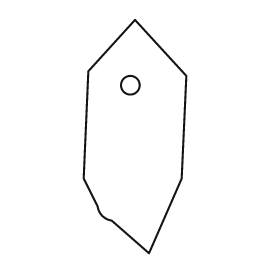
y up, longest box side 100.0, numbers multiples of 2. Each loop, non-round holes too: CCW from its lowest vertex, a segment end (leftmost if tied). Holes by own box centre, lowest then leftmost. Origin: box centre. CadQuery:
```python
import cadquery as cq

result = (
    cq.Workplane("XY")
    .moveTo(6.0, -50.0)
    .lineTo(20.0, -18.0)
    .lineTo(22.0, 26.0)
    .lineTo(0.0, 50.0)
    .lineTo(-20.0, 28.0)
    .lineTo(-22.0, -18.0)
    .lineTo(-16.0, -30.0)
    .threePointArc((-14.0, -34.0), (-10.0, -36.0))
    .close()
    .moveTo(-2.0, 22.0)
    .circle(4.0)
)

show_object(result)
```